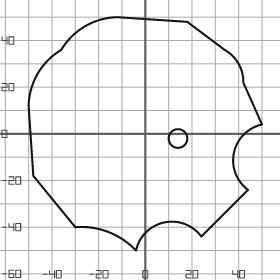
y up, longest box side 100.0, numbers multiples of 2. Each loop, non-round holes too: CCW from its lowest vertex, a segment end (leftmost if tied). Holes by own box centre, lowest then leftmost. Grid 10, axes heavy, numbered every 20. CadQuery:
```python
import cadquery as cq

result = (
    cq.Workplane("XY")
    .moveTo(-4.0, -50.0)
    .threePointArc((8.0, -38.0), (24.0, -44.0))
    .lineTo(44.0, -24.0)
    .threePointArc((38.0, -8.0), (50.0, 4.0))
    .lineTo(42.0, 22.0)
    .threePointArc((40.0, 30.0), (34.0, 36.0))
    .lineTo(18.0, 48.0)
    .lineTo(-12.0, 50.0)
    .threePointArc((-26.0, 46.0), (-36.0, 36.0))
    .threePointArc((-46.0, 26.0), (-50.0, 12.0))
    .lineTo(-48.0, -18.0)
    .lineTo(-30.0, -40.0)
    .threePointArc((-16.0, -42.0), (-4.0, -50.0))
    .close()
    .moveTo(14.0, -2.0)
    .circle(4.0)
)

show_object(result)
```